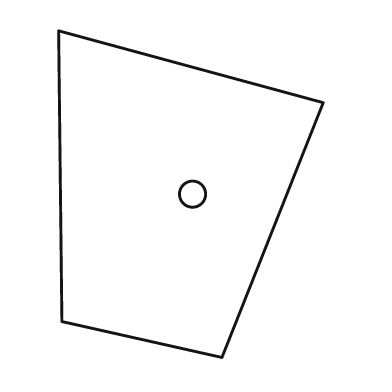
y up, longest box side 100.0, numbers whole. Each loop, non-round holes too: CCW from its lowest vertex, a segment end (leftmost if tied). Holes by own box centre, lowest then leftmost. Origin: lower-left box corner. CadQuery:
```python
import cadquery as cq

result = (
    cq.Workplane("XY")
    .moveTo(50.0, 0.0)
    .lineTo(81.0, 78.0)
    .lineTo(0.0, 100.0)
    .lineTo(1.0, 11.0)
    .close()
    .moveTo(41.0, 50.0)
    .circle(4.0)
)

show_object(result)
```